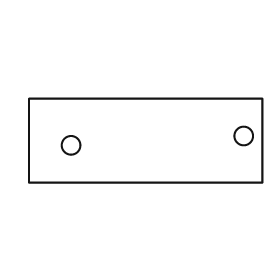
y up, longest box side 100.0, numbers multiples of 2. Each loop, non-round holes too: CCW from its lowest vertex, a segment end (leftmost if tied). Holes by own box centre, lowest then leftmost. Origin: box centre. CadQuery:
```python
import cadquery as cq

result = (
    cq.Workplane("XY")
    .moveTo(-50.0, -18.0)
    .lineTo(50.0, -18.0)
    .lineTo(50.0, 18.0)
    .lineTo(-50.0, 18.0)
    .close()
    .moveTo(-32.0, -2.0)
    .circle(4.0)
    .moveTo(42.0, 2.0)
    .circle(4.0)
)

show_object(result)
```